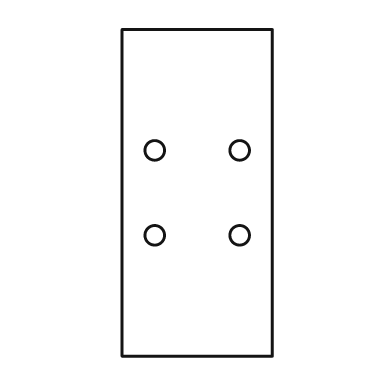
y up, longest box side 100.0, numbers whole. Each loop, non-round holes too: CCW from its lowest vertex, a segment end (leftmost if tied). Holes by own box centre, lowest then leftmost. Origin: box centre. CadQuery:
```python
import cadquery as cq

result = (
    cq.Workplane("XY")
    .moveTo(-23.0, -50.0)
    .lineTo(23.0, -50.0)
    .lineTo(23.0, 50.0)
    .lineTo(-23.0, 50.0)
    .close()
    .moveTo(-13.0, -13.0)
    .circle(3.0)
    .moveTo(13.0, -13.0)
    .circle(3.0)
    .moveTo(-13.0, 13.0)
    .circle(3.0)
    .moveTo(13.0, 13.0)
    .circle(3.0)
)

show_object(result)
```